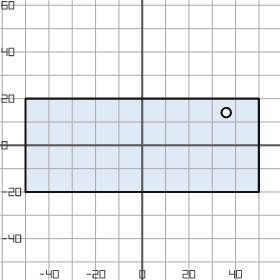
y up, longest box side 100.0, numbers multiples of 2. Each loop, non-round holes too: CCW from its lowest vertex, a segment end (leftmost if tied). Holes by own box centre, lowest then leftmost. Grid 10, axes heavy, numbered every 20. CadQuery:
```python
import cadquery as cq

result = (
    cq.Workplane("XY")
    .moveTo(-50.0, -20.0)
    .lineTo(50.0, -20.0)
    .lineTo(50.0, 20.0)
    .lineTo(-50.0, 20.0)
    .close()
    .moveTo(36.0, 14.0)
    .circle(2.0)
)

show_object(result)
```